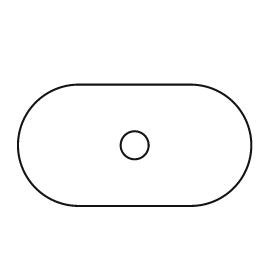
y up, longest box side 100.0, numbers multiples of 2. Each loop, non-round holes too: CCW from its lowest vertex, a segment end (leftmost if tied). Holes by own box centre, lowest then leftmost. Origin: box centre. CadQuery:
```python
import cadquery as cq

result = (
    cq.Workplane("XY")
    .moveTo(-24.0, -26.0)
    .lineTo(24.0, -26.0)
    .threePointArc((50.0, 0.0), (24.0, 26.0))
    .lineTo(-24.0, 26.0)
    .threePointArc((-50.0, 0.0), (-24.0, -26.0))
    .close()
    .moveTo(0.0, 0.0)
    .circle(6.0)
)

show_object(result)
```